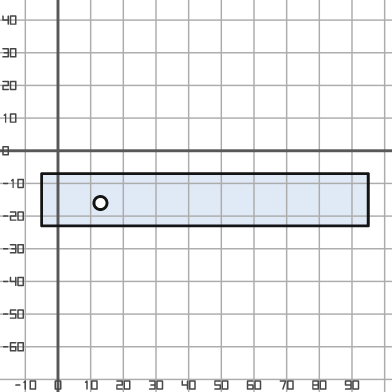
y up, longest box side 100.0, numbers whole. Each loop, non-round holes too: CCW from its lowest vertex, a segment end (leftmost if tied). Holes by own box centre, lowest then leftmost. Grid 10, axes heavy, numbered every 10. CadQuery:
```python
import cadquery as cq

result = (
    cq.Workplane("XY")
    .moveTo(-5.0, -23.0)
    .lineTo(95.0, -23.0)
    .lineTo(95.0, -7.0)
    .lineTo(-5.0, -7.0)
    .close()
    .moveTo(13.0, -16.0)
    .circle(2.0)
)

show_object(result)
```